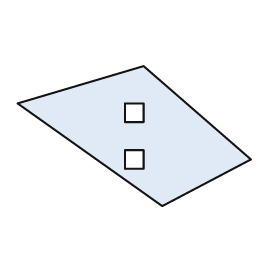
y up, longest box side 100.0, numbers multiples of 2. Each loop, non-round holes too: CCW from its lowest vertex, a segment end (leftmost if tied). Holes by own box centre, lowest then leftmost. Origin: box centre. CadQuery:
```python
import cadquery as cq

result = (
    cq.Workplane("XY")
    .moveTo(12.0, -30.0)
    .lineTo(50.0, -10.0)
    .lineTo(4.0, 30.0)
    .lineTo(-50.0, 14.0)
    .close()
    .moveTo(-4.0, -14.0)
    .lineTo(4.0, -14.0)
    .lineTo(4.0, -6.0)
    .lineTo(-4.0, -6.0)
    .close()
    .moveTo(-4.0, 6.0)
    .lineTo(4.0, 6.0)
    .lineTo(4.0, 14.0)
    .lineTo(-4.0, 14.0)
    .close()
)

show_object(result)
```